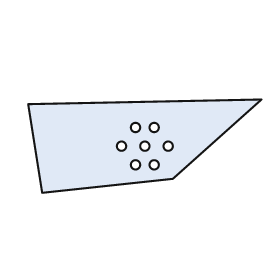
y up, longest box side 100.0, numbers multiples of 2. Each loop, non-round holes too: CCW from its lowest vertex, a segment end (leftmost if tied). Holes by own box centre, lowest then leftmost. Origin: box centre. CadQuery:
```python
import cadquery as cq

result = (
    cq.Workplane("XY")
    .moveTo(-44.0, -20.0)
    .lineTo(12.0, -14.0)
    .lineTo(50.0, 20.0)
    .lineTo(-50.0, 18.0)
    .close()
    .moveTo(-4.0, -8.0)
    .circle(2.0)
    .moveTo(4.0, -8.0)
    .circle(2.0)
    .moveTo(-10.0, 0.0)
    .circle(2.0)
    .moveTo(0.0, 0.0)
    .circle(2.0)
    .moveTo(10.0, 0.0)
    .circle(2.0)
    .moveTo(-4.0, 8.0)
    .circle(2.0)
    .moveTo(4.0, 8.0)
    .circle(2.0)
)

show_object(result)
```